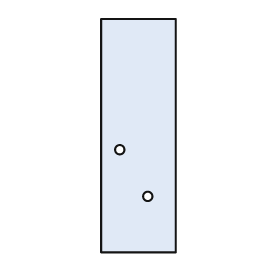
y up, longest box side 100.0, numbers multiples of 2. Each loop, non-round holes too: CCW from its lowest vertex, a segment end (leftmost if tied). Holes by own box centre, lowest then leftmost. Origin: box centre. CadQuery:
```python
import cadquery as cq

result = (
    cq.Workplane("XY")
    .moveTo(-16.0, -50.0)
    .lineTo(16.0, -50.0)
    .lineTo(16.0, 50.0)
    .lineTo(-16.0, 50.0)
    .close()
    .moveTo(4.0, -26.0)
    .circle(2.0)
    .moveTo(-8.0, -6.0)
    .circle(2.0)
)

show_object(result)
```